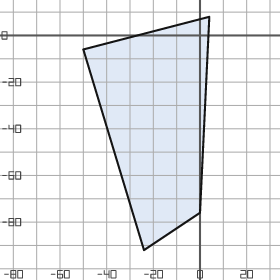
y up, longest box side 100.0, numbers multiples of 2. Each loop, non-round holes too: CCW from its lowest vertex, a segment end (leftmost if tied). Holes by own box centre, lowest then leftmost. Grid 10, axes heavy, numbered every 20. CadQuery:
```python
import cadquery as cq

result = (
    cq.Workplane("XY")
    .moveTo(-24.0, -92.0)
    .lineTo(0.0, -76.0)
    .lineTo(4.0, 8.0)
    .lineTo(-50.0, -6.0)
    .close()
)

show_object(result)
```